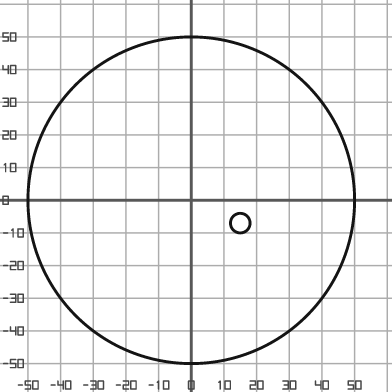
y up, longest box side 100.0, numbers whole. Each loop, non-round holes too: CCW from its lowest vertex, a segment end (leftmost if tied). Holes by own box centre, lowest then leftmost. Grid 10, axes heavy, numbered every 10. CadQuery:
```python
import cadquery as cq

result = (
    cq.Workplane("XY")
    .moveTo(0.0, 0.0)
    .circle(50.0)
    .moveTo(15.0, -7.0)
    .circle(3.0)
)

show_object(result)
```